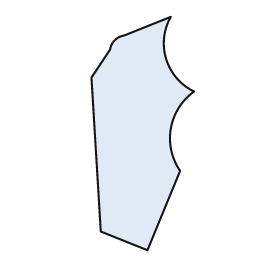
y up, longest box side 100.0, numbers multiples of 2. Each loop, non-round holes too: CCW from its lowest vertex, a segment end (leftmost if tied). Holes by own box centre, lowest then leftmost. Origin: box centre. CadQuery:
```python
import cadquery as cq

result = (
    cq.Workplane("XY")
    .moveTo(2.0, -50.0)
    .lineTo(16.0, -16.0)
    .threePointArc((12.0, 2.0), (22.0, 18.0))
    .threePointArc((10.0, 32.0), (12.0, 50.0))
    .lineTo(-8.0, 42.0)
    .threePointArc((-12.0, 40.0), (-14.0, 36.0))
    .lineTo(-22.0, 24.0)
    .lineTo(-18.0, -42.0)
    .close()
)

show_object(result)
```